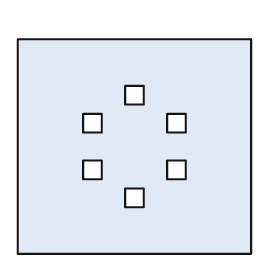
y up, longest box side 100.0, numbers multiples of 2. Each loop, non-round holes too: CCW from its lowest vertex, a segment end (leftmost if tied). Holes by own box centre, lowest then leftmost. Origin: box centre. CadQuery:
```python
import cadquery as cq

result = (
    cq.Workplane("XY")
    .moveTo(-50.0, -46.0)
    .lineTo(50.0, -46.0)
    .lineTo(50.0, 46.0)
    .lineTo(-50.0, 46.0)
    .close()
    .moveTo(-4.0, -26.0)
    .lineTo(4.0, -26.0)
    .lineTo(4.0, -18.0)
    .lineTo(-4.0, -18.0)
    .close()
    .moveTo(-22.0, -14.0)
    .lineTo(-14.0, -14.0)
    .lineTo(-14.0, -6.0)
    .lineTo(-22.0, -6.0)
    .close()
    .moveTo(14.0, -14.0)
    .lineTo(22.0, -14.0)
    .lineTo(22.0, -6.0)
    .lineTo(14.0, -6.0)
    .close()
    .moveTo(-22.0, 6.0)
    .lineTo(-14.0, 6.0)
    .lineTo(-14.0, 14.0)
    .lineTo(-22.0, 14.0)
    .close()
    .moveTo(14.0, 6.0)
    .lineTo(22.0, 6.0)
    .lineTo(22.0, 14.0)
    .lineTo(14.0, 14.0)
    .close()
    .moveTo(-4.0, 18.0)
    .lineTo(4.0, 18.0)
    .lineTo(4.0, 26.0)
    .lineTo(-4.0, 26.0)
    .close()
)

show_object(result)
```